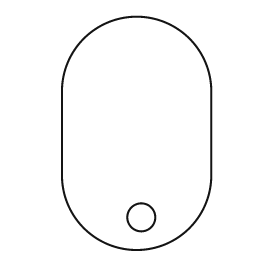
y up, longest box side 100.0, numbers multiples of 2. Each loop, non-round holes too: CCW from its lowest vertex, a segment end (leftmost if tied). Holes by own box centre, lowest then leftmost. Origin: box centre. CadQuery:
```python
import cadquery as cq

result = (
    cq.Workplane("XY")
    .moveTo(-32.0, -18.0)
    .threePointArc((0.0, -50.0), (32.0, -18.0))
    .lineTo(32.0, 18.0)
    .threePointArc((0.0, 50.0), (-32.0, 18.0))
    .close()
    .moveTo(2.0, -36.0)
    .circle(6.0)
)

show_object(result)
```